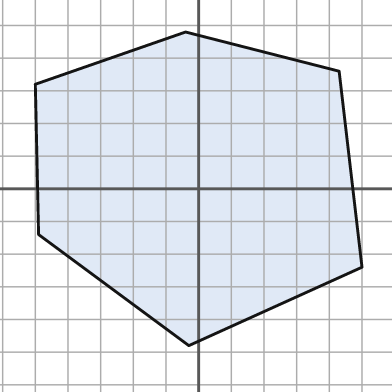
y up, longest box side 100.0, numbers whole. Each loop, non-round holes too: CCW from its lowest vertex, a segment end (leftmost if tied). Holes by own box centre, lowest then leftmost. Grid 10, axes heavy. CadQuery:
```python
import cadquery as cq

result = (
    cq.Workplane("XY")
    .moveTo(-3.0, -48.0)
    .lineTo(50.0, -24.0)
    .lineTo(43.0, 36.0)
    .lineTo(-4.0, 48.0)
    .lineTo(-50.0, 32.0)
    .lineTo(-49.0, -14.0)
    .close()
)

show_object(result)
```